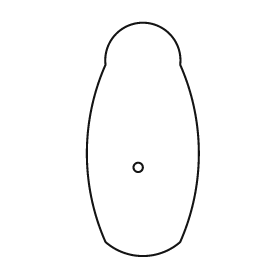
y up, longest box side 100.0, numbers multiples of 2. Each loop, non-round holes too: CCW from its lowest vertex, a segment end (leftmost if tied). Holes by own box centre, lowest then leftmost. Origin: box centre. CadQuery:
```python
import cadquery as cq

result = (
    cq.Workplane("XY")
    .moveTo(-16.0, -44.0)
    .threePointArc((0.0, -50.0), (16.0, -44.0))
    .threePointArc((24.0, -6.0), (16.0, 32.0))
    .threePointArc((0.0, 50.0), (-16.0, 32.0))
    .threePointArc((-24.0, -6.0), (-16.0, -44.0))
    .close()
    .moveTo(-2.0, -12.0)
    .circle(2.0)
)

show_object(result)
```